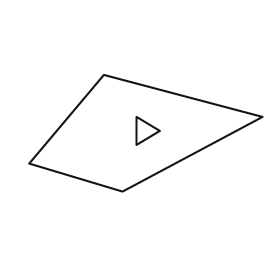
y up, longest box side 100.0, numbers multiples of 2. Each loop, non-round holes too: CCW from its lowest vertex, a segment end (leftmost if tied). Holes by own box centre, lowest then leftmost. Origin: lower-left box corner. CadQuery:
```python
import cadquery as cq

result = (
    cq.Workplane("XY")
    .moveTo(40.0, 0.0)
    .lineTo(100.0, 32.0)
    .lineTo(32.0, 50.0)
    .lineTo(0.0, 12.0)
    .close()
    .moveTo(46.0, 20.0)
    .lineTo(56.0, 26.0)
    .lineTo(46.0, 32.0)
    .close()
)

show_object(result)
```